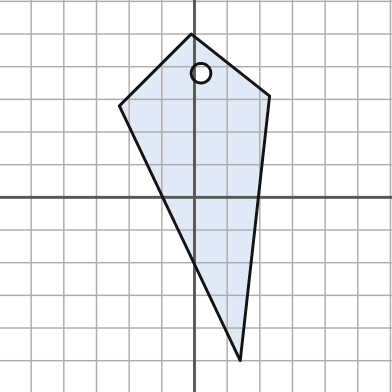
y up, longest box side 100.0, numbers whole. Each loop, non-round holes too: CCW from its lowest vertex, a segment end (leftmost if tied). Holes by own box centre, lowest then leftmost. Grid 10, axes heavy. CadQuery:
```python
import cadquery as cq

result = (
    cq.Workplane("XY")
    .moveTo(14.0, -50.0)
    .lineTo(23.0, 31.0)
    .lineTo(-1.0, 50.0)
    .lineTo(-23.0, 28.0)
    .close()
    .moveTo(2.0, 38.0)
    .circle(3.0)
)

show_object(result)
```